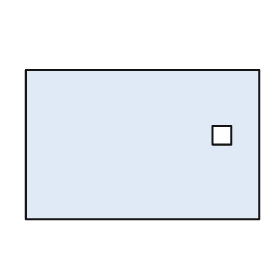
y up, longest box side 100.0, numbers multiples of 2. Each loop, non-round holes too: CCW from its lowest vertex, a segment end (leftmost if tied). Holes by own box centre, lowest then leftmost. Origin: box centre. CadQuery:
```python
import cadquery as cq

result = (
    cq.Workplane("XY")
    .moveTo(-50.0, -32.0)
    .lineTo(50.0, -32.0)
    .lineTo(50.0, 32.0)
    .lineTo(-50.0, 32.0)
    .close()
    .moveTo(30.0, 0.0)
    .lineTo(38.0, 0.0)
    .lineTo(38.0, 8.0)
    .lineTo(30.0, 8.0)
    .close()
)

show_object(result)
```